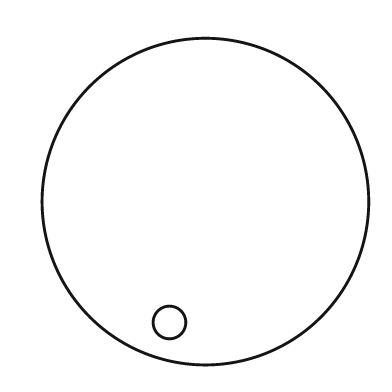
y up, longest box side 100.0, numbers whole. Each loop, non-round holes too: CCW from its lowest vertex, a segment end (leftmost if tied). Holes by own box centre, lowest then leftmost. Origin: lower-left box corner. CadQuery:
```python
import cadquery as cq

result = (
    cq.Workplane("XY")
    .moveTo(50.0, 50.0)
    .circle(50.0)
    .moveTo(39.0, 13.0)
    .circle(5.0)
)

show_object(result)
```